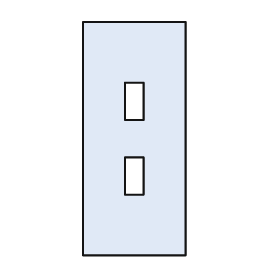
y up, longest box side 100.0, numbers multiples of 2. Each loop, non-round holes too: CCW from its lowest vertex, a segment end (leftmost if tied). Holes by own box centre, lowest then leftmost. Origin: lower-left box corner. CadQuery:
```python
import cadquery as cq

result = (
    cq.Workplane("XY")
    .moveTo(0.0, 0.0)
    .lineTo(44.0, 0.0)
    .lineTo(44.0, 100.0)
    .lineTo(0.0, 100.0)
    .close()
    .moveTo(18.0, 26.0)
    .lineTo(26.0, 26.0)
    .lineTo(26.0, 42.0)
    .lineTo(18.0, 42.0)
    .close()
    .moveTo(18.0, 58.0)
    .lineTo(26.0, 58.0)
    .lineTo(26.0, 74.0)
    .lineTo(18.0, 74.0)
    .close()
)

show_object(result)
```